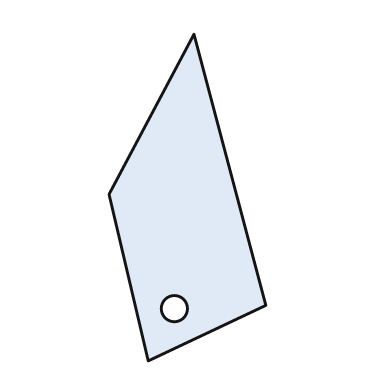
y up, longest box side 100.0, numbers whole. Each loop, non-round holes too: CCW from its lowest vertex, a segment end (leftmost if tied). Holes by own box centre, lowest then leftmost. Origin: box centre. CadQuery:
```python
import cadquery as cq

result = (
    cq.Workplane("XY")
    .moveTo(-12.0, -50.0)
    .lineTo(24.0, -33.0)
    .lineTo(2.0, 50.0)
    .lineTo(-24.0, 1.0)
    .close()
    .moveTo(-4.0, -34.0)
    .circle(4.0)
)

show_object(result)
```